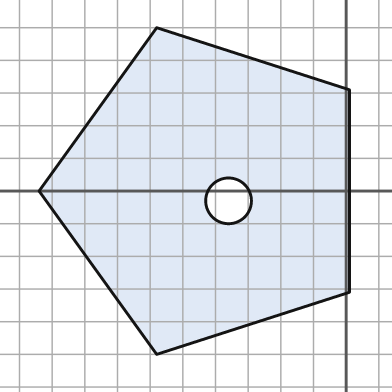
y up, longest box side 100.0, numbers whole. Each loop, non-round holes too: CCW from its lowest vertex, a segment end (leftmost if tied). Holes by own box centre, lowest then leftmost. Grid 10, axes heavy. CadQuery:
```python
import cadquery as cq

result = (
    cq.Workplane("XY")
    .moveTo(-58.0, -50.0)
    .lineTo(1.0, -31.0)
    .lineTo(1.0, 31.0)
    .lineTo(-58.0, 50.0)
    .lineTo(-94.0, 0.0)
    .close()
    .moveTo(-36.0, -3.0)
    .circle(7.0)
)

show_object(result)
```